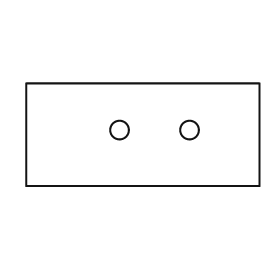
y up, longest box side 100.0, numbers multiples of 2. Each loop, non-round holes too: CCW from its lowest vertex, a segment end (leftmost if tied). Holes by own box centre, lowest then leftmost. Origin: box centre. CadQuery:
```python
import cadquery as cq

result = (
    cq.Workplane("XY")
    .moveTo(-50.0, -22.0)
    .lineTo(50.0, -22.0)
    .lineTo(50.0, 22.0)
    .lineTo(-50.0, 22.0)
    .close()
    .moveTo(-10.0, 2.0)
    .circle(4.0)
    .moveTo(20.0, 2.0)
    .circle(4.0)
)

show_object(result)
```